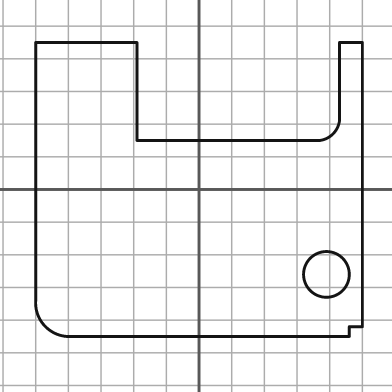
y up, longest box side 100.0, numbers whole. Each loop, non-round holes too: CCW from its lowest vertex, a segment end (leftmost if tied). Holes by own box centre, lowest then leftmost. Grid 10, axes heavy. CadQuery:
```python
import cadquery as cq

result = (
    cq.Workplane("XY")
    .moveTo(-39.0, -45.0)
    .lineTo(46.0, -45.0)
    .lineTo(46.0, -42.0)
    .lineTo(50.0, -42.0)
    .lineTo(50.0, 45.0)
    .lineTo(43.0, 45.0)
    .lineTo(43.0, 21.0)
    .threePointArc((41.0, 17.0), (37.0, 15.0))
    .lineTo(-19.0, 15.0)
    .lineTo(-19.0, 45.0)
    .lineTo(-50.0, 45.0)
    .lineTo(-50.0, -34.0)
    .threePointArc((-47.0, -42.0), (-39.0, -45.0))
    .close()
    .moveTo(39.0, -26.0)
    .circle(7.0)
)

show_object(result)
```